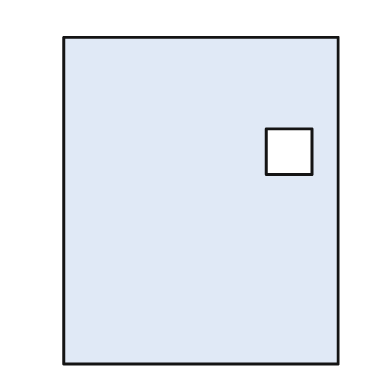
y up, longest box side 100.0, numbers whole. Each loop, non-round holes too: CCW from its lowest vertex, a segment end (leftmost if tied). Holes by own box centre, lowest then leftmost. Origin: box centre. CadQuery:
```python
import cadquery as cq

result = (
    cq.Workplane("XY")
    .moveTo(-42.0, -50.0)
    .lineTo(42.0, -50.0)
    .lineTo(42.0, 50.0)
    .lineTo(-42.0, 50.0)
    .close()
    .moveTo(20.0, 8.0)
    .lineTo(34.0, 8.0)
    .lineTo(34.0, 22.0)
    .lineTo(20.0, 22.0)
    .close()
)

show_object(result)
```